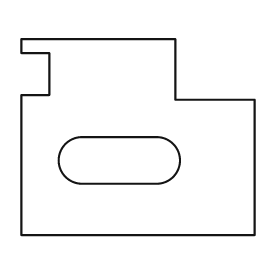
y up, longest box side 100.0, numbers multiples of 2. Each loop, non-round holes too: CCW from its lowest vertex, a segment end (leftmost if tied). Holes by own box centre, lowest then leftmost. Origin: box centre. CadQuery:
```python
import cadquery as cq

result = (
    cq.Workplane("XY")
    .moveTo(-50.0, -42.0)
    .lineTo(50.0, -42.0)
    .lineTo(50.0, 16.0)
    .lineTo(16.0, 16.0)
    .lineTo(16.0, 42.0)
    .lineTo(-50.0, 42.0)
    .lineTo(-50.0, 36.0)
    .lineTo(-38.0, 36.0)
    .lineTo(-38.0, 18.0)
    .lineTo(-50.0, 18.0)
    .close()
    .moveTo(-24.0, -20.0)
    .lineTo(8.0, -20.0)
    .threePointArc((18.0, -10.0), (8.0, 0.0))
    .lineTo(-24.0, 0.0)
    .threePointArc((-34.0, -10.0), (-24.0, -20.0))
    .close()
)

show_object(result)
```